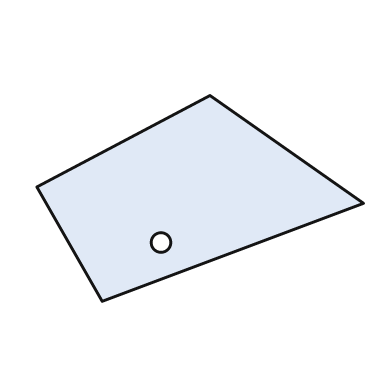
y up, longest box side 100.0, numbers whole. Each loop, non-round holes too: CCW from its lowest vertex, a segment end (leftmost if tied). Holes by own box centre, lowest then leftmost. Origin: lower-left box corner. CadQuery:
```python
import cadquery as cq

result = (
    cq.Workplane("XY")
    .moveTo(20.0, 0.0)
    .lineTo(100.0, 30.0)
    .lineTo(53.0, 63.0)
    .lineTo(0.0, 35.0)
    .close()
    .moveTo(38.0, 18.0)
    .circle(3.0)
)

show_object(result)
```